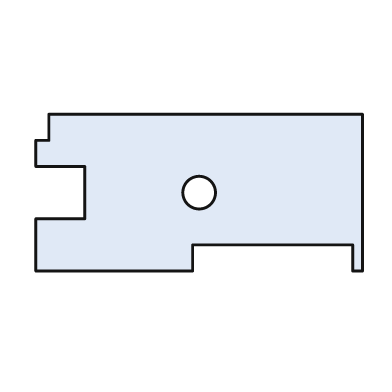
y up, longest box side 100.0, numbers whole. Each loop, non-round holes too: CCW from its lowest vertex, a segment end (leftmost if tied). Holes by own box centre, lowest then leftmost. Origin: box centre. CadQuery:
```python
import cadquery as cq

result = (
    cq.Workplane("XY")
    .moveTo(-50.0, -24.0)
    .lineTo(-2.0, -24.0)
    .lineTo(-2.0, -16.0)
    .lineTo(47.0, -16.0)
    .lineTo(47.0, -24.0)
    .lineTo(50.0, -24.0)
    .lineTo(50.0, 24.0)
    .lineTo(-46.0, 24.0)
    .lineTo(-46.0, 16.0)
    .lineTo(-50.0, 16.0)
    .lineTo(-50.0, 8.0)
    .lineTo(-35.0, 8.0)
    .lineTo(-35.0, -8.0)
    .lineTo(-50.0, -8.0)
    .close()
    .moveTo(0.0, 0.0)
    .circle(5.0)
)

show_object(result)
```